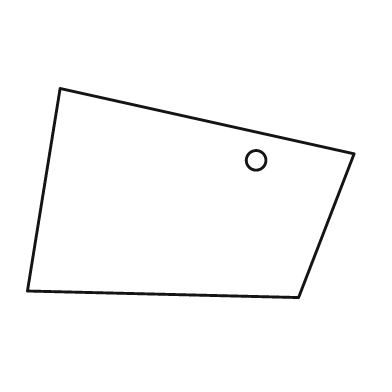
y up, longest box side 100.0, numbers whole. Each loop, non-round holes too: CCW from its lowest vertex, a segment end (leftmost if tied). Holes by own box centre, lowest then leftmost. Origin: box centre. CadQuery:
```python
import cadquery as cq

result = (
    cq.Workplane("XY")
    .moveTo(33.0, -32.0)
    .lineTo(50.0, 12.0)
    .lineTo(-40.0, 32.0)
    .lineTo(-50.0, -30.0)
    .close()
    .moveTo(20.0, 10.0)
    .circle(3.0)
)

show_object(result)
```